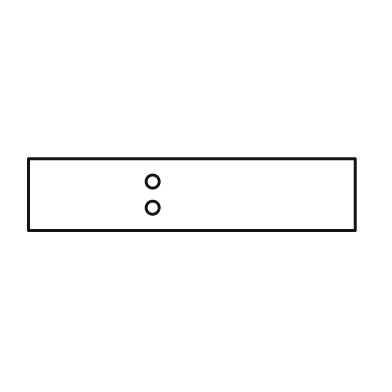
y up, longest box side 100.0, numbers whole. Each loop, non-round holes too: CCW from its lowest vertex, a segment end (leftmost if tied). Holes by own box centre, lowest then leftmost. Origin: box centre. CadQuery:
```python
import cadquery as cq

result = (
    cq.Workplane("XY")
    .moveTo(-50.0, -11.0)
    .lineTo(50.0, -11.0)
    .lineTo(50.0, 11.0)
    .lineTo(-50.0, 11.0)
    .close()
    .moveTo(-12.0, -4.0)
    .circle(2.0)
    .moveTo(-12.0, 4.0)
    .circle(2.0)
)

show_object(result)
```